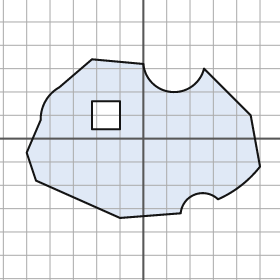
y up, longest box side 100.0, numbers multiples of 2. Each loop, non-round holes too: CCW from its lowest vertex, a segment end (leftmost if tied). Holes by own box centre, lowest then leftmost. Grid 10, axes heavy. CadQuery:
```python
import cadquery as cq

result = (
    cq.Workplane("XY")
    .moveTo(-10.0, -34.0)
    .lineTo(16.0, -32.0)
    .threePointArc((22.0, -24.0), (32.0, -26.0))
    .threePointArc((42.0, -20.0), (50.0, -12.0))
    .lineTo(46.0, 10.0)
    .lineTo(26.0, 30.0)
    .threePointArc((12.0, 20.0), (0.0, 32.0))
    .lineTo(-22.0, 34.0)
    .lineTo(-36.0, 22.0)
    .threePointArc((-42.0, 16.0), (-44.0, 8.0))
    .lineTo(-50.0, -6.0)
    .lineTo(-46.0, -18.0)
    .close()
    .moveTo(-22.0, 4.0)
    .lineTo(-10.0, 4.0)
    .lineTo(-10.0, 16.0)
    .lineTo(-22.0, 16.0)
    .close()
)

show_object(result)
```